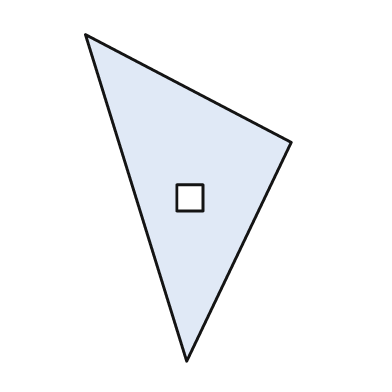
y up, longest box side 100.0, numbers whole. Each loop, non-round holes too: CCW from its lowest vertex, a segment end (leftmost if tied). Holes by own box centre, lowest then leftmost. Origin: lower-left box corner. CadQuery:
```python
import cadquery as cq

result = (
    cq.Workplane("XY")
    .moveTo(31.0, 0.0)
    .lineTo(63.0, 67.0)
    .lineTo(0.0, 100.0)
    .close()
    .moveTo(28.0, 46.0)
    .lineTo(36.0, 46.0)
    .lineTo(36.0, 54.0)
    .lineTo(28.0, 54.0)
    .close()
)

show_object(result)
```